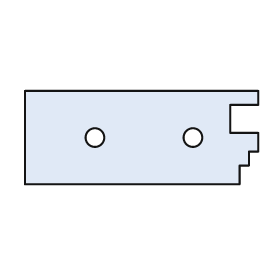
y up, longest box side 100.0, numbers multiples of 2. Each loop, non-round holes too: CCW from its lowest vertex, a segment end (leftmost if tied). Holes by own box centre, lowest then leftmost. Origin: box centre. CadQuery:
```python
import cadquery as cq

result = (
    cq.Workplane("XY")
    .moveTo(-50.0, -20.0)
    .lineTo(42.0, -20.0)
    .lineTo(42.0, -12.0)
    .lineTo(46.0, -12.0)
    .lineTo(46.0, -6.0)
    .lineTo(50.0, -6.0)
    .lineTo(50.0, 2.0)
    .lineTo(38.0, 2.0)
    .lineTo(38.0, 14.0)
    .lineTo(50.0, 14.0)
    .lineTo(50.0, 20.0)
    .lineTo(-50.0, 20.0)
    .close()
    .moveTo(-20.0, 0.0)
    .circle(4.0)
    .moveTo(22.0, 0.0)
    .circle(4.0)
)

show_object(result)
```